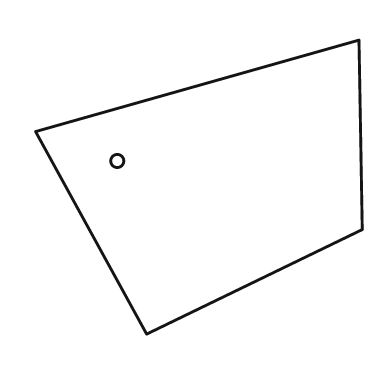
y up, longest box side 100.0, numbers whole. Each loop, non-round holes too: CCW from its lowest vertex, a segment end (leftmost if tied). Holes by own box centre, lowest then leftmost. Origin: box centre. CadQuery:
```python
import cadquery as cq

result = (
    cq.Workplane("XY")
    .moveTo(-16.0, -45.0)
    .lineTo(50.0, -13.0)
    .lineTo(49.0, 45.0)
    .lineTo(-50.0, 17.0)
    .close()
    .moveTo(-25.0, 8.0)
    .circle(2.0)
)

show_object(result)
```